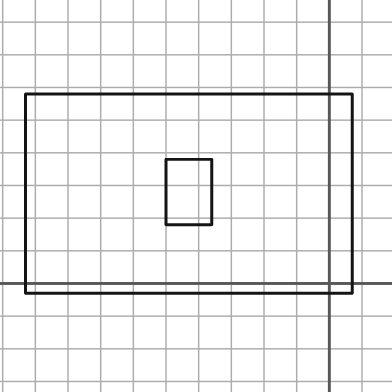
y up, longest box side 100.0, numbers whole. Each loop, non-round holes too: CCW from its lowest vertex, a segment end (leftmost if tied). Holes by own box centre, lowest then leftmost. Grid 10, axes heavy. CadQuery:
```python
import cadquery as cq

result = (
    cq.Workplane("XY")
    .moveTo(-93.0, -3.0)
    .lineTo(7.0, -3.0)
    .lineTo(7.0, 58.0)
    .lineTo(-93.0, 58.0)
    .close()
    .moveTo(-50.0, 18.0)
    .lineTo(-36.0, 18.0)
    .lineTo(-36.0, 38.0)
    .lineTo(-50.0, 38.0)
    .close()
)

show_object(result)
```